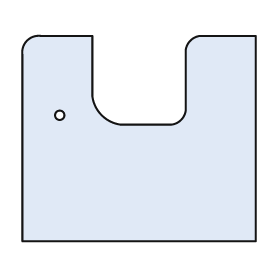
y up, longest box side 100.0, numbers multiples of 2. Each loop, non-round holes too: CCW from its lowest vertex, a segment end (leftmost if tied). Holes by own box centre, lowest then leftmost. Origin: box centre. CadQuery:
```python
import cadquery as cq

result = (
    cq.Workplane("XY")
    .moveTo(-50.0, -44.0)
    .lineTo(50.0, -44.0)
    .lineTo(50.0, 44.0)
    .lineTo(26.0, 44.0)
    .threePointArc((22.0, 42.0), (20.0, 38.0))
    .lineTo(20.0, 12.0)
    .threePointArc((18.0, 8.0), (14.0, 6.0))
    .lineTo(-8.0, 6.0)
    .threePointArc((-16.0, 10.0), (-20.0, 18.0))
    .lineTo(-20.0, 44.0)
    .lineTo(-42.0, 44.0)
    .threePointArc((-48.0, 42.0), (-50.0, 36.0))
    .close()
    .moveTo(-34.0, 10.0)
    .circle(2.0)
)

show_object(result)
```